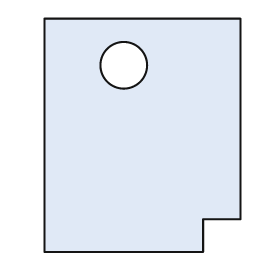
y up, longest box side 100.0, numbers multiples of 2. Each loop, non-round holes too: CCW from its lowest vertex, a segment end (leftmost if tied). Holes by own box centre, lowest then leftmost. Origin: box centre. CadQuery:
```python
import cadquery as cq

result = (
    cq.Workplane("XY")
    .moveTo(-42.0, -50.0)
    .lineTo(26.0, -50.0)
    .lineTo(26.0, -36.0)
    .lineTo(42.0, -36.0)
    .lineTo(42.0, 50.0)
    .lineTo(-42.0, 50.0)
    .close()
    .moveTo(-8.0, 30.0)
    .circle(10.0)
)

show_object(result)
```